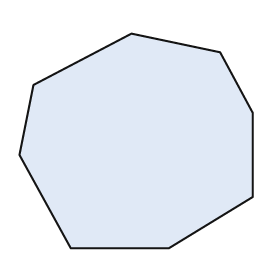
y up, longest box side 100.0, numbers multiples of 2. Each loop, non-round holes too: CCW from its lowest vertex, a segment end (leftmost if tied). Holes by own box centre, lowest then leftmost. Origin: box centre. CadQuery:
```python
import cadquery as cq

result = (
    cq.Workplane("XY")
    .moveTo(-28.0, -46.0)
    .lineTo(14.0, -46.0)
    .lineTo(50.0, -24.0)
    .lineTo(50.0, 12.0)
    .lineTo(36.0, 38.0)
    .lineTo(-2.0, 46.0)
    .lineTo(-44.0, 24.0)
    .lineTo(-50.0, -6.0)
    .close()
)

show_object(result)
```